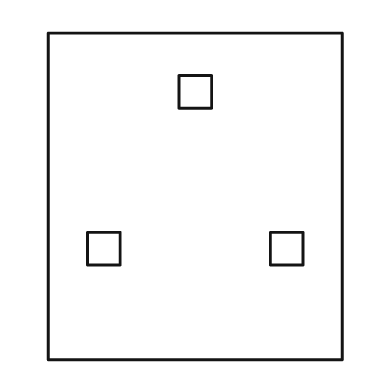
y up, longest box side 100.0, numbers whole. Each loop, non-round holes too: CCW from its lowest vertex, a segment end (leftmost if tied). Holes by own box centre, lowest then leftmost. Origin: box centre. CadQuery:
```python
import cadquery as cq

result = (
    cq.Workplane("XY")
    .moveTo(-45.0, -50.0)
    .lineTo(45.0, -50.0)
    .lineTo(45.0, 50.0)
    .lineTo(-45.0, 50.0)
    .close()
    .moveTo(-33.0, -21.0)
    .lineTo(-23.0, -21.0)
    .lineTo(-23.0, -11.0)
    .lineTo(-33.0, -11.0)
    .close()
    .moveTo(23.0, -21.0)
    .lineTo(33.0, -21.0)
    .lineTo(33.0, -11.0)
    .lineTo(23.0, -11.0)
    .close()
    .moveTo(-5.0, 27.0)
    .lineTo(5.0, 27.0)
    .lineTo(5.0, 37.0)
    .lineTo(-5.0, 37.0)
    .close()
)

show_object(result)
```